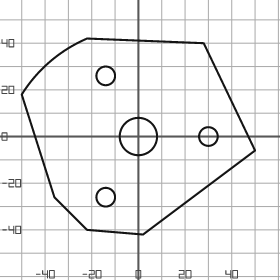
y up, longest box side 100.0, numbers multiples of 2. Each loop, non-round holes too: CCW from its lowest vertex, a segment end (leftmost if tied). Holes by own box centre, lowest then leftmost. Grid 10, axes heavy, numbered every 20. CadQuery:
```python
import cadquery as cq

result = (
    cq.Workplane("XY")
    .moveTo(2.0, -42.0)
    .lineTo(50.0, -6.0)
    .lineTo(28.0, 40.0)
    .lineTo(-22.0, 42.0)
    .threePointArc((-38.0, 32.0), (-50.0, 18.0))
    .lineTo(-36.0, -26.0)
    .lineTo(-22.0, -40.0)
    .close()
    .moveTo(-14.0, -26.0)
    .circle(4.0)
    .moveTo(0.0, 0.0)
    .circle(8.0)
    .moveTo(30.0, 0.0)
    .circle(4.0)
    .moveTo(-14.0, 26.0)
    .circle(4.0)
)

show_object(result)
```